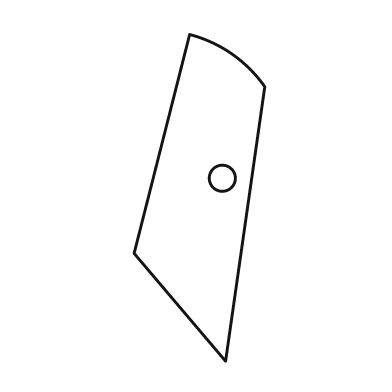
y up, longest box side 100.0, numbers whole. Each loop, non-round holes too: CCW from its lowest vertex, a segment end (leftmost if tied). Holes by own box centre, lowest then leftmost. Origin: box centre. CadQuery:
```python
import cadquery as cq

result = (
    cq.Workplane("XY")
    .moveTo(8.0, -50.0)
    .lineTo(20.0, 34.0)
    .threePointArc((10.0, 44.0), (-3.0, 50.0))
    .lineTo(-20.0, -17.0)
    .close()
    .moveTo(7.0, 6.0)
    .circle(4.0)
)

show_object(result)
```